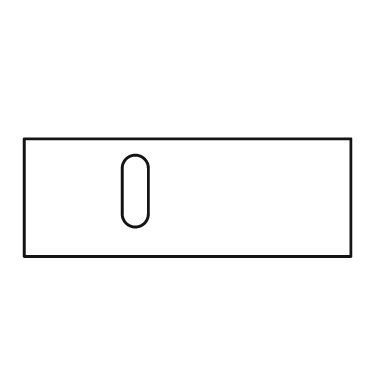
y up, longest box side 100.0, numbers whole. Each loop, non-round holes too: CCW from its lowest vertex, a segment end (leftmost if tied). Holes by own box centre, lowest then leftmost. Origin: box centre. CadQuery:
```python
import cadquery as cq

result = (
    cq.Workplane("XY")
    .moveTo(-50.0, -18.0)
    .lineTo(50.0, -18.0)
    .lineTo(50.0, 18.0)
    .lineTo(-50.0, 18.0)
    .close()
    .moveTo(-20.0, -5.0)
    .threePointArc((-16.0, -9.0), (-12.0, -5.0))
    .lineTo(-12.0, 9.0)
    .threePointArc((-16.0, 13.0), (-20.0, 9.0))
    .close()
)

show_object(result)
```